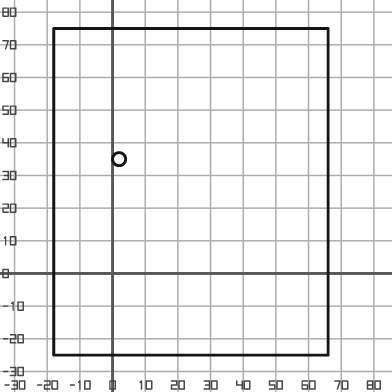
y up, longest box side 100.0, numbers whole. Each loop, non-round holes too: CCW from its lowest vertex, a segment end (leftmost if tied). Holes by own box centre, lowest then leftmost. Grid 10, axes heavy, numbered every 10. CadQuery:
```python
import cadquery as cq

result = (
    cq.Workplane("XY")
    .moveTo(-18.0, -25.0)
    .lineTo(66.0, -25.0)
    .lineTo(66.0, 75.0)
    .lineTo(-18.0, 75.0)
    .close()
    .moveTo(2.0, 35.0)
    .circle(2.0)
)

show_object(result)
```